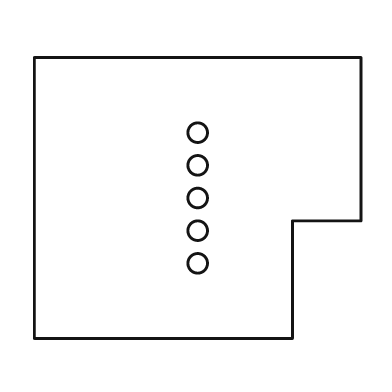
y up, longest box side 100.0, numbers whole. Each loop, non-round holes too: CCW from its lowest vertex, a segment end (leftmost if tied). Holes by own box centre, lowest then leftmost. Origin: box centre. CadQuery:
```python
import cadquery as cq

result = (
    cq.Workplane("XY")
    .moveTo(-50.0, -43.0)
    .lineTo(29.0, -43.0)
    .lineTo(29.0, -7.0)
    .lineTo(50.0, -7.0)
    .lineTo(50.0, 43.0)
    .lineTo(-50.0, 43.0)
    .close()
    .moveTo(0.0, -20.0)
    .circle(3.0)
    .moveTo(0.0, -10.0)
    .circle(3.0)
    .moveTo(0.0, 0.0)
    .circle(3.0)
    .moveTo(0.0, 10.0)
    .circle(3.0)
    .moveTo(0.0, 20.0)
    .circle(3.0)
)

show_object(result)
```